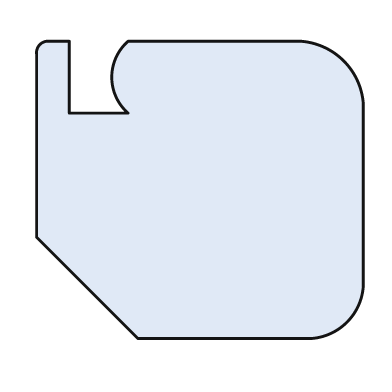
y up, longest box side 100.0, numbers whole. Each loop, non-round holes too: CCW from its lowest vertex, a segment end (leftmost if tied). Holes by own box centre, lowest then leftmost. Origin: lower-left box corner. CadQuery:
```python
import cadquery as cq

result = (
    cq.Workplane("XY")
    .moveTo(31.0, 0.0)
    .lineTo(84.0, 0.0)
    .threePointArc((95.0, 5.0), (100.0, 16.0))
    .lineTo(100.0, 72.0)
    .threePointArc((94.0, 85.0), (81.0, 91.0))
    .lineTo(28.0, 91.0)
    .threePointArc((23.0, 80.0), (28.0, 69.0))
    .lineTo(10.0, 69.0)
    .lineTo(10.0, 91.0)
    .lineTo(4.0, 91.0)
    .threePointArc((1.0, 90.0), (0.0, 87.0))
    .lineTo(0.0, 31.0)
    .close()
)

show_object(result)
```